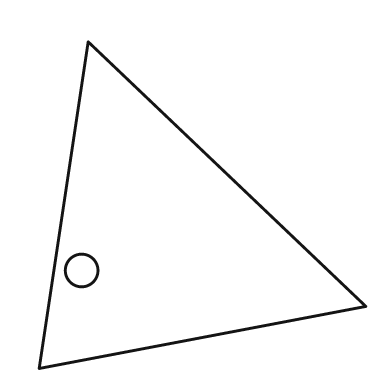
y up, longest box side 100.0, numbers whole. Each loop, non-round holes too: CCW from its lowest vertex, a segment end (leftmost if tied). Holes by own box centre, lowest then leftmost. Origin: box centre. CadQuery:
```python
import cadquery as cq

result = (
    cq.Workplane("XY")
    .moveTo(-50.0, -50.0)
    .lineTo(50.0, -31.0)
    .lineTo(-35.0, 50.0)
    .close()
    .moveTo(-37.0, -20.0)
    .circle(5.0)
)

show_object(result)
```